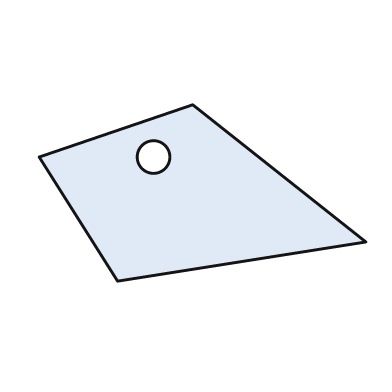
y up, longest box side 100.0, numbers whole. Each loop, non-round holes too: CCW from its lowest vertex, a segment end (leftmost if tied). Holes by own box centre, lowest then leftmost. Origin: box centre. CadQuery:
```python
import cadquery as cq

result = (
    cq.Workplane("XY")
    .moveTo(-26.0, -27.0)
    .lineTo(50.0, -15.0)
    .lineTo(-3.0, 27.0)
    .lineTo(-50.0, 11.0)
    .close()
    .moveTo(-15.0, 11.0)
    .circle(5.0)
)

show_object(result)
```